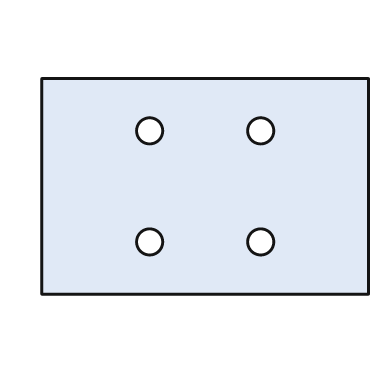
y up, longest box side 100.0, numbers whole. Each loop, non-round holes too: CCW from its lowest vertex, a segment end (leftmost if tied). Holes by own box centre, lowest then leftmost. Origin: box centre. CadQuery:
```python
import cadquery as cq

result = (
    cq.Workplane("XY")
    .moveTo(-50.0, -33.0)
    .lineTo(50.0, -33.0)
    .lineTo(50.0, 33.0)
    .lineTo(-50.0, 33.0)
    .close()
    .moveTo(-17.0, -17.0)
    .circle(4.0)
    .moveTo(17.0, -17.0)
    .circle(4.0)
    .moveTo(-17.0, 17.0)
    .circle(4.0)
    .moveTo(17.0, 17.0)
    .circle(4.0)
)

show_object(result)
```